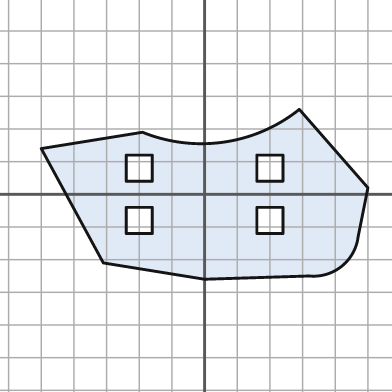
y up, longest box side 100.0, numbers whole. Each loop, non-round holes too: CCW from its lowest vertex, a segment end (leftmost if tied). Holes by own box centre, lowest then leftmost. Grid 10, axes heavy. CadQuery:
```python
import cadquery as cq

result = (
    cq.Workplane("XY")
    .moveTo(0.0, -26.0)
    .lineTo(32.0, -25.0)
    .threePointArc((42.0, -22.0), (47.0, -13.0))
    .lineTo(50.0, 2.0)
    .lineTo(29.0, 26.0)
    .threePointArc((6.0, 16.0), (-19.0, 19.0))
    .lineTo(-50.0, 14.0)
    .lineTo(-31.0, -21.0)
    .close()
    .moveTo(-24.0, -12.0)
    .lineTo(-16.0, -12.0)
    .lineTo(-16.0, -4.0)
    .lineTo(-24.0, -4.0)
    .close()
    .moveTo(16.0, -12.0)
    .lineTo(24.0, -12.0)
    .lineTo(24.0, -4.0)
    .lineTo(16.0, -4.0)
    .close()
    .moveTo(-24.0, 4.0)
    .lineTo(-16.0, 4.0)
    .lineTo(-16.0, 12.0)
    .lineTo(-24.0, 12.0)
    .close()
    .moveTo(16.0, 4.0)
    .lineTo(24.0, 4.0)
    .lineTo(24.0, 12.0)
    .lineTo(16.0, 12.0)
    .close()
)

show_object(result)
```